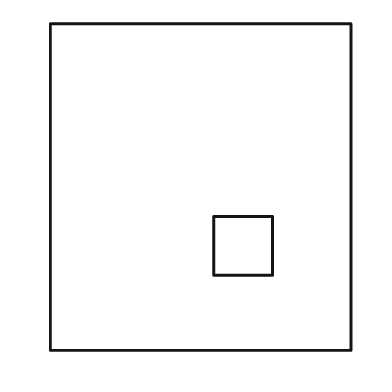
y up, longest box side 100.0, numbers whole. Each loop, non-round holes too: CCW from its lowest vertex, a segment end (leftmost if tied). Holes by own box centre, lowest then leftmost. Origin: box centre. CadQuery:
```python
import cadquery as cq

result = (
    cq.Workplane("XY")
    .moveTo(-46.0, -50.0)
    .lineTo(46.0, -50.0)
    .lineTo(46.0, 50.0)
    .lineTo(-46.0, 50.0)
    .close()
    .moveTo(4.0, -27.0)
    .lineTo(22.0, -27.0)
    .lineTo(22.0, -9.0)
    .lineTo(4.0, -9.0)
    .close()
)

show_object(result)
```